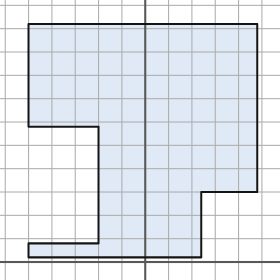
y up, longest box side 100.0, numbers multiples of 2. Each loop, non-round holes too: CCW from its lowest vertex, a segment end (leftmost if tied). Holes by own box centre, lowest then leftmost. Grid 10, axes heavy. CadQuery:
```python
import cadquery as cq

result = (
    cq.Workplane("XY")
    .moveTo(-50.0, 2.0)
    .lineTo(24.0, 2.0)
    .lineTo(24.0, 30.0)
    .lineTo(48.0, 30.0)
    .lineTo(48.0, 102.0)
    .lineTo(-50.0, 102.0)
    .lineTo(-50.0, 58.0)
    .lineTo(-20.0, 58.0)
    .lineTo(-20.0, 8.0)
    .lineTo(-50.0, 8.0)
    .close()
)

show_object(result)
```